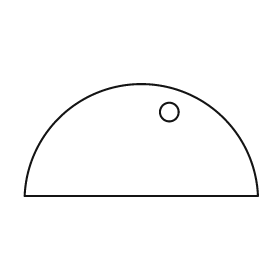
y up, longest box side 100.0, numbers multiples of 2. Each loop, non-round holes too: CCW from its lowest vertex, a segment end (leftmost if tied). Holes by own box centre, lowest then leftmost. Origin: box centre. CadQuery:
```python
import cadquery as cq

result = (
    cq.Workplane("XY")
    .moveTo(-50.0, -24.0)
    .lineTo(50.0, -24.0)
    .threePointArc((0.0, 24.0), (-50.0, -24.0))
    .close()
    .moveTo(12.0, 12.0)
    .circle(4.0)
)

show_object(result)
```